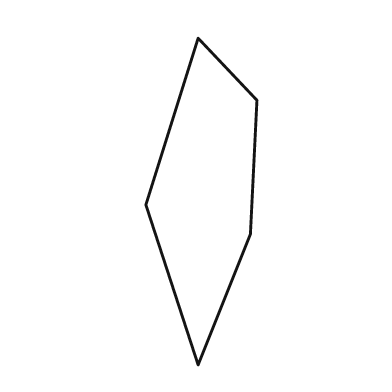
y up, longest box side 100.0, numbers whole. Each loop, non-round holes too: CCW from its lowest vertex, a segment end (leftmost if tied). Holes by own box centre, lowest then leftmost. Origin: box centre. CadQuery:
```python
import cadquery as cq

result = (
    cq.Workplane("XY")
    .moveTo(-1.0, -50.0)
    .lineTo(15.0, -10.0)
    .lineTo(17.0, 31.0)
    .lineTo(-1.0, 50.0)
    .lineTo(-17.0, -1.0)
    .close()
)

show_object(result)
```